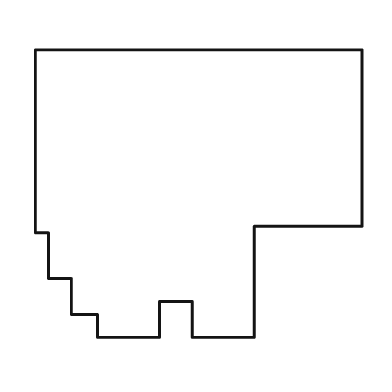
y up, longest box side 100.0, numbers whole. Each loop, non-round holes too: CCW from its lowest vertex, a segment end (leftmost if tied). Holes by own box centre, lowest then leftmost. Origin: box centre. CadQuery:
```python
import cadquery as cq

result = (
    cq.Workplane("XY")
    .moveTo(-31.0, -44.0)
    .lineTo(-12.0, -44.0)
    .lineTo(-12.0, -33.0)
    .lineTo(-2.0, -33.0)
    .lineTo(-2.0, -44.0)
    .lineTo(17.0, -44.0)
    .lineTo(17.0, -10.0)
    .lineTo(50.0, -10.0)
    .lineTo(50.0, 44.0)
    .lineTo(-50.0, 44.0)
    .lineTo(-50.0, -12.0)
    .lineTo(-46.0, -12.0)
    .lineTo(-46.0, -26.0)
    .lineTo(-39.0, -26.0)
    .lineTo(-39.0, -37.0)
    .lineTo(-31.0, -37.0)
    .close()
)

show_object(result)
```